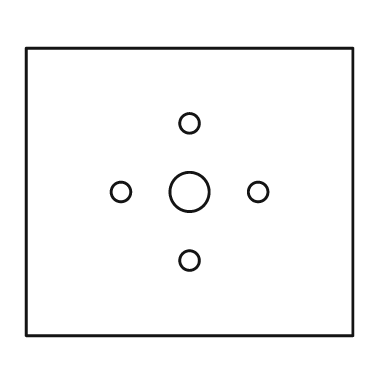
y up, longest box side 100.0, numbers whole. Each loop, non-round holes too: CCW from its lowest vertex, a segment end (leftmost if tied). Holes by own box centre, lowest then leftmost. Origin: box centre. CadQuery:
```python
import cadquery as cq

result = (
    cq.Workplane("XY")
    .moveTo(-50.0, -44.0)
    .lineTo(50.0, -44.0)
    .lineTo(50.0, 44.0)
    .lineTo(-50.0, 44.0)
    .close()
    .moveTo(0.0, -21.0)
    .circle(3.0)
    .moveTo(-21.0, 0.0)
    .circle(3.0)
    .moveTo(0.0, 0.0)
    .circle(6.0)
    .moveTo(21.0, 0.0)
    .circle(3.0)
    .moveTo(0.0, 21.0)
    .circle(3.0)
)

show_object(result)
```